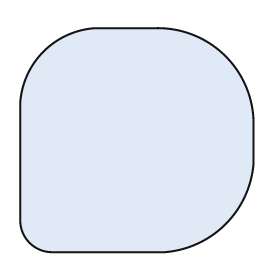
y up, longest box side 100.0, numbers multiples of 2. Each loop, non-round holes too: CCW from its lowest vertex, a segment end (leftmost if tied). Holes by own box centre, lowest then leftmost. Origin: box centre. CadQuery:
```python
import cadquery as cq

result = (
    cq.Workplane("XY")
    .moveTo(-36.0, -48.0)
    .lineTo(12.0, -48.0)
    .threePointArc((38.0, -36.0), (50.0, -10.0))
    .lineTo(50.0, 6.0)
    .threePointArc((38.0, 36.0), (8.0, 48.0))
    .lineTo(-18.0, 48.0)
    .threePointArc((-40.0, 38.0), (-50.0, 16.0))
    .lineTo(-50.0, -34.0)
    .threePointArc((-46.0, -44.0), (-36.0, -48.0))
    .close()
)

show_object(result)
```